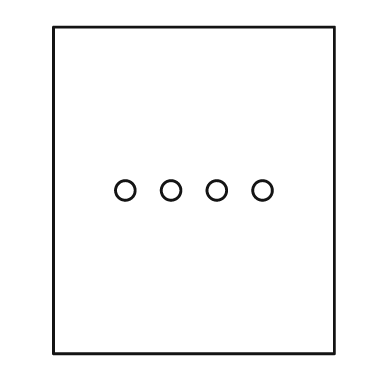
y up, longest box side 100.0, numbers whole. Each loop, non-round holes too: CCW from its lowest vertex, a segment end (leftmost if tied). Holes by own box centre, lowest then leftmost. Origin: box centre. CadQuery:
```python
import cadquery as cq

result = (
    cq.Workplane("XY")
    .moveTo(-43.0, -50.0)
    .lineTo(43.0, -50.0)
    .lineTo(43.0, 50.0)
    .lineTo(-43.0, 50.0)
    .close()
    .moveTo(-21.0, 0.0)
    .circle(3.0)
    .moveTo(-7.0, 0.0)
    .circle(3.0)
    .moveTo(7.0, 0.0)
    .circle(3.0)
    .moveTo(21.0, 0.0)
    .circle(3.0)
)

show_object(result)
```